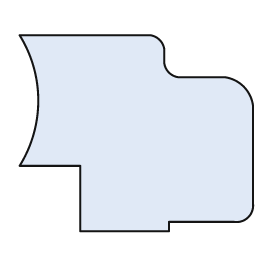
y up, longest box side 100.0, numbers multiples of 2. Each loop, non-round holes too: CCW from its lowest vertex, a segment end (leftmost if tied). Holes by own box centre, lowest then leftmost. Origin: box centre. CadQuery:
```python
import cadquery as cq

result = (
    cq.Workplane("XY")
    .moveTo(-24.0, -42.0)
    .lineTo(14.0, -42.0)
    .lineTo(14.0, -38.0)
    .lineTo(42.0, -38.0)
    .threePointArc((48.0, -36.0), (50.0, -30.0))
    .lineTo(50.0, 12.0)
    .threePointArc((46.0, 20.0), (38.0, 24.0))
    .lineTo(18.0, 24.0)
    .threePointArc((14.0, 26.0), (12.0, 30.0))
    .lineTo(12.0, 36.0)
    .threePointArc((10.0, 40.0), (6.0, 42.0))
    .lineTo(-50.0, 42.0)
    .threePointArc((-42.0, 14.0), (-50.0, -14.0))
    .lineTo(-24.0, -14.0)
    .close()
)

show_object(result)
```